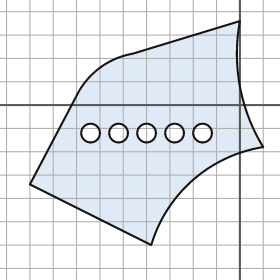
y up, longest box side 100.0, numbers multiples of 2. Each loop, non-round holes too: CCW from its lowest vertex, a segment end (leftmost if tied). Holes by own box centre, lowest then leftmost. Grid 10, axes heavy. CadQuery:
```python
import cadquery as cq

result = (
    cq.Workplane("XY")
    .moveTo(-38.0, -60.0)
    .threePointArc((-20.0, -32.0), (10.0, -18.0))
    .threePointArc((0.0, 8.0), (0.0, 36.0))
    .lineTo(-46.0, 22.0)
    .threePointArc((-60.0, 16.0), (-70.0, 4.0))
    .lineTo(-90.0, -34.0)
    .close()
    .moveTo(-64.0, -12.0)
    .circle(4.0)
    .moveTo(-52.0, -12.0)
    .circle(4.0)
    .moveTo(-40.0, -12.0)
    .circle(4.0)
    .moveTo(-28.0, -12.0)
    .circle(4.0)
    .moveTo(-16.0, -12.0)
    .circle(4.0)
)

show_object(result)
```